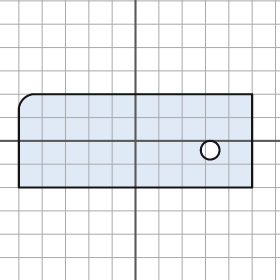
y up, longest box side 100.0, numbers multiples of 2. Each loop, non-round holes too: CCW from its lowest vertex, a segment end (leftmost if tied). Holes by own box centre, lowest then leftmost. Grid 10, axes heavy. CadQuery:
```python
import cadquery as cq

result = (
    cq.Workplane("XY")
    .moveTo(-50.0, -20.0)
    .lineTo(50.0, -20.0)
    .lineTo(50.0, 20.0)
    .lineTo(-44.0, 20.0)
    .threePointArc((-48.0, 18.0), (-50.0, 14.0))
    .close()
    .moveTo(32.0, -4.0)
    .circle(4.0)
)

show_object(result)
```